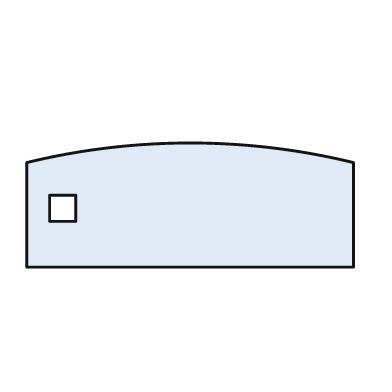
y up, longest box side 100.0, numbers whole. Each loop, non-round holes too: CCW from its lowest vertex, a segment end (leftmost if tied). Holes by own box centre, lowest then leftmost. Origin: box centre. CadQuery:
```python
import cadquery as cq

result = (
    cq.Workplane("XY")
    .moveTo(-50.0, -19.0)
    .lineTo(50.0, -19.0)
    .lineTo(50.0, 13.0)
    .threePointArc((0.0, 19.0), (-50.0, 13.0))
    .close()
    .moveTo(-43.0, -5.0)
    .lineTo(-35.0, -5.0)
    .lineTo(-35.0, 3.0)
    .lineTo(-43.0, 3.0)
    .close()
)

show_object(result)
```